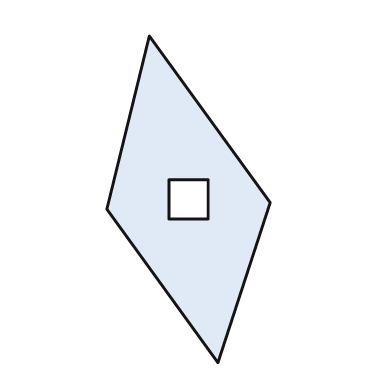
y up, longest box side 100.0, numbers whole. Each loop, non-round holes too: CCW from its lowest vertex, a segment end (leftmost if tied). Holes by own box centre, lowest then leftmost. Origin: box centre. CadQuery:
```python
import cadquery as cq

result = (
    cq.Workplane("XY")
    .moveTo(9.0, -50.0)
    .lineTo(25.0, -1.0)
    .lineTo(-12.0, 50.0)
    .lineTo(-25.0, -3.0)
    .close()
    .moveTo(-6.0, -6.0)
    .lineTo(6.0, -6.0)
    .lineTo(6.0, 6.0)
    .lineTo(-6.0, 6.0)
    .close()
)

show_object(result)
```